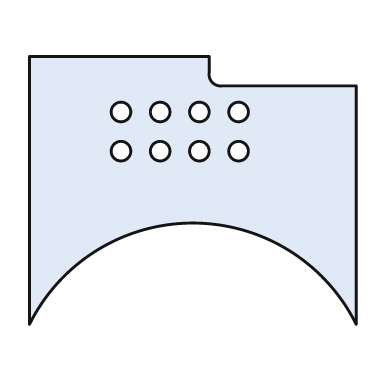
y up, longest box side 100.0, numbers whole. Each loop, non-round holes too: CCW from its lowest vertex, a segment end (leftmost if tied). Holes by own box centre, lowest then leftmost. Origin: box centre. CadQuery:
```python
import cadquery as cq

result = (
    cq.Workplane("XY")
    .moveTo(-50.0, -41.0)
    .threePointArc((0.0, -10.0), (50.0, -41.0))
    .lineTo(50.0, 32.0)
    .lineTo(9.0, 32.0)
    .threePointArc((6.0, 33.0), (5.0, 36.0))
    .lineTo(5.0, 41.0)
    .lineTo(-50.0, 41.0)
    .close()
    .moveTo(-22.0, 12.0)
    .circle(3.0)
    .moveTo(-10.0, 12.0)
    .circle(3.0)
    .moveTo(2.0, 12.0)
    .circle(3.0)
    .moveTo(14.0, 12.0)
    .circle(3.0)
    .moveTo(-22.0, 24.0)
    .circle(3.0)
    .moveTo(-10.0, 24.0)
    .circle(3.0)
    .moveTo(2.0, 24.0)
    .circle(3.0)
    .moveTo(14.0, 24.0)
    .circle(3.0)
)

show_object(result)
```